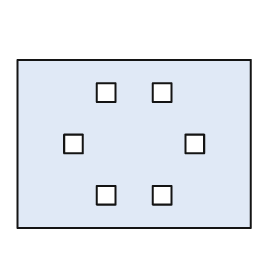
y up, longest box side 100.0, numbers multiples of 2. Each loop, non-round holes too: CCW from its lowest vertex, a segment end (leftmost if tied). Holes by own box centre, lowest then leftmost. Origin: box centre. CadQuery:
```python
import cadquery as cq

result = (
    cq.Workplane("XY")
    .moveTo(-50.0, -36.0)
    .lineTo(50.0, -36.0)
    .lineTo(50.0, 36.0)
    .lineTo(-50.0, 36.0)
    .close()
    .moveTo(-16.0, -26.0)
    .lineTo(-8.0, -26.0)
    .lineTo(-8.0, -18.0)
    .lineTo(-16.0, -18.0)
    .close()
    .moveTo(8.0, -26.0)
    .lineTo(16.0, -26.0)
    .lineTo(16.0, -18.0)
    .lineTo(8.0, -18.0)
    .close()
    .moveTo(-30.0, -4.0)
    .lineTo(-22.0, -4.0)
    .lineTo(-22.0, 4.0)
    .lineTo(-30.0, 4.0)
    .close()
    .moveTo(22.0, -4.0)
    .lineTo(30.0, -4.0)
    .lineTo(30.0, 4.0)
    .lineTo(22.0, 4.0)
    .close()
    .moveTo(-16.0, 18.0)
    .lineTo(-8.0, 18.0)
    .lineTo(-8.0, 26.0)
    .lineTo(-16.0, 26.0)
    .close()
    .moveTo(8.0, 18.0)
    .lineTo(16.0, 18.0)
    .lineTo(16.0, 26.0)
    .lineTo(8.0, 26.0)
    .close()
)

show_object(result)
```